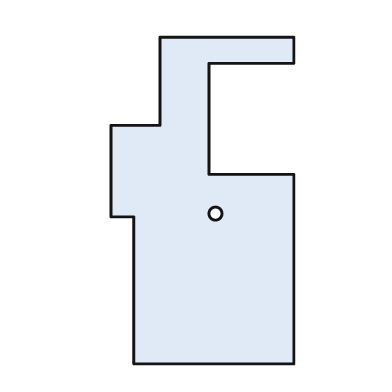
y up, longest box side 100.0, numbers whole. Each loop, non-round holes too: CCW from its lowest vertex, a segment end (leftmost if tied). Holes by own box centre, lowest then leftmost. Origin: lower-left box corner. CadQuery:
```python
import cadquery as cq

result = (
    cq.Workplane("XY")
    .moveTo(7.0, 0.0)
    .lineTo(56.0, 0.0)
    .lineTo(56.0, 58.0)
    .lineTo(30.0, 58.0)
    .lineTo(30.0, 92.0)
    .lineTo(56.0, 92.0)
    .lineTo(56.0, 100.0)
    .lineTo(15.0, 100.0)
    .lineTo(15.0, 73.0)
    .lineTo(0.0, 73.0)
    .lineTo(0.0, 45.0)
    .lineTo(7.0, 45.0)
    .close()
    .moveTo(32.0, 46.0)
    .circle(2.0)
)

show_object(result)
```